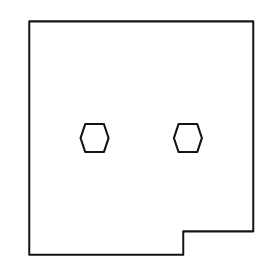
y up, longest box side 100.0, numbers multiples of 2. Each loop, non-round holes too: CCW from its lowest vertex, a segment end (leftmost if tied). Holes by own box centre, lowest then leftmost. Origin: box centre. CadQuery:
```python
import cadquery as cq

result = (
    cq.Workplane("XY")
    .moveTo(-48.0, -50.0)
    .lineTo(18.0, -50.0)
    .lineTo(18.0, -40.0)
    .lineTo(48.0, -40.0)
    .lineTo(48.0, 50.0)
    .lineTo(-48.0, 50.0)
    .close()
    .moveTo(-24.0, -6.0)
    .lineTo(-16.0, -6.0)
    .lineTo(-14.0, 0.0)
    .lineTo(-16.0, 6.0)
    .lineTo(-24.0, 6.0)
    .lineTo(-26.0, 0.0)
    .close()
    .moveTo(16.0, -6.0)
    .lineTo(24.0, -6.0)
    .lineTo(26.0, 0.0)
    .lineTo(24.0, 6.0)
    .lineTo(16.0, 6.0)
    .lineTo(14.0, 0.0)
    .close()
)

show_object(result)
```